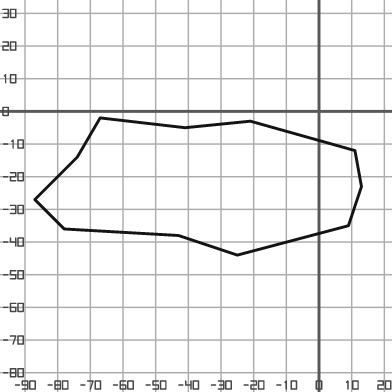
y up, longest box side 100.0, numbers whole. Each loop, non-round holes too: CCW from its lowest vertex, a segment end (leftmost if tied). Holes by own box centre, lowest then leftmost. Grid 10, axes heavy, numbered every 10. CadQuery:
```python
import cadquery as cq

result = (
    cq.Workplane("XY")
    .moveTo(-25.0, -44.0)
    .lineTo(9.0, -35.0)
    .lineTo(13.0, -23.0)
    .lineTo(11.0, -12.0)
    .lineTo(-21.0, -3.0)
    .lineTo(-41.0, -5.0)
    .lineTo(-67.0, -2.0)
    .lineTo(-74.0, -14.0)
    .lineTo(-87.0, -27.0)
    .lineTo(-78.0, -36.0)
    .lineTo(-43.0, -38.0)
    .close()
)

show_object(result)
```